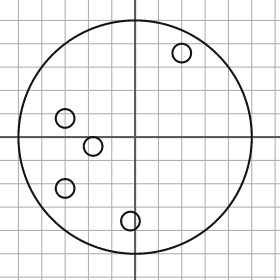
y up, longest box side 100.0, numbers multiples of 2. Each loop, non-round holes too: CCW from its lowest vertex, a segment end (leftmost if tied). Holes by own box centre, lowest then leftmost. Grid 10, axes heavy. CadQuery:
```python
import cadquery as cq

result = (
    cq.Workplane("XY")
    .moveTo(0.0, 0.0)
    .circle(50.0)
    .moveTo(-2.0, -36.0)
    .circle(4.0)
    .moveTo(-30.0, -22.0)
    .circle(4.0)
    .moveTo(-18.0, -4.0)
    .circle(4.0)
    .moveTo(-30.0, 8.0)
    .circle(4.0)
    .moveTo(20.0, 36.0)
    .circle(4.0)
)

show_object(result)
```